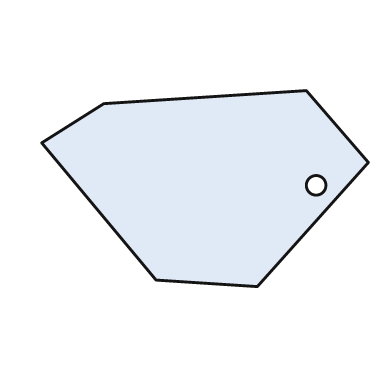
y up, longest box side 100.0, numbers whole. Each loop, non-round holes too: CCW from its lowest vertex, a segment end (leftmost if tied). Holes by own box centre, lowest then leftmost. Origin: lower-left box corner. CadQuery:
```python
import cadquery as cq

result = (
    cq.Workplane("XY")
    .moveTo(66.0, 0.0)
    .lineTo(100.0, 38.0)
    .lineTo(81.0, 60.0)
    .lineTo(19.0, 56.0)
    .lineTo(0.0, 44.0)
    .lineTo(35.0, 2.0)
    .close()
    .moveTo(84.0, 31.0)
    .circle(3.0)
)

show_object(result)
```